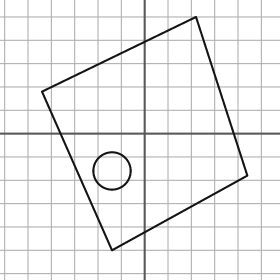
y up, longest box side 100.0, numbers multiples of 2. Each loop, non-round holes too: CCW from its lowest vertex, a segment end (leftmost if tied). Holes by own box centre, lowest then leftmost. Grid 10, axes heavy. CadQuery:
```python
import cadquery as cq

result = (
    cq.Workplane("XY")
    .moveTo(-14.0, -50.0)
    .lineTo(44.0, -18.0)
    .lineTo(22.0, 50.0)
    .lineTo(-44.0, 18.0)
    .close()
    .moveTo(-14.0, -16.0)
    .circle(8.0)
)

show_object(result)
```